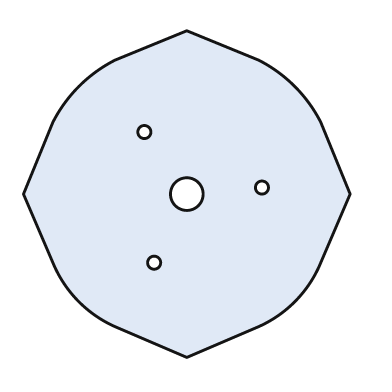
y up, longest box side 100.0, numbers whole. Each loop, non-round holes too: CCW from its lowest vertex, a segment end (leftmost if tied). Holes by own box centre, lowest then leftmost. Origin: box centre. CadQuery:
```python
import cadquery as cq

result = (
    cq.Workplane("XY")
    .moveTo(0.0, -50.0)
    .lineTo(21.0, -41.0)
    .threePointArc((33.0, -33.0), (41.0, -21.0))
    .lineTo(50.0, 0.0)
    .lineTo(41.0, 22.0)
    .threePointArc((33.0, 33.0), (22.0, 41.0))
    .lineTo(0.0, 50.0)
    .lineTo(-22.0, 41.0)
    .threePointArc((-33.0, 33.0), (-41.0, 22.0))
    .lineTo(-50.0, 0.0)
    .lineTo(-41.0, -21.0)
    .threePointArc((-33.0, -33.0), (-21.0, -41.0))
    .close()
    .moveTo(-10.0, -21.0)
    .circle(2.0)
    .moveTo(0.0, 0.0)
    .circle(5.0)
    .moveTo(23.0, 2.0)
    .circle(2.0)
    .moveTo(-13.0, 19.0)
    .circle(2.0)
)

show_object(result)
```